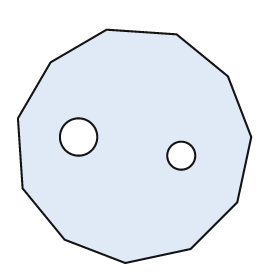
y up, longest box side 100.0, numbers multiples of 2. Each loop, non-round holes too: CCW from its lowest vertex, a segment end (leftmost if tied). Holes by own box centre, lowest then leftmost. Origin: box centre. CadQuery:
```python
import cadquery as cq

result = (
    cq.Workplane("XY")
    .moveTo(-4.0, -50.0)
    .lineTo(24.0, -44.0)
    .lineTo(44.0, -24.0)
    .lineTo(50.0, 4.0)
    .lineTo(40.0, 30.0)
    .lineTo(18.0, 48.0)
    .lineTo(-12.0, 50.0)
    .lineTo(-36.0, 36.0)
    .lineTo(-50.0, 12.0)
    .lineTo(-48.0, -18.0)
    .lineTo(-30.0, -40.0)
    .close()
    .moveTo(20.0, -4.0)
    .circle(6.0)
    .moveTo(-24.0, 4.0)
    .circle(8.0)
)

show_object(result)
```